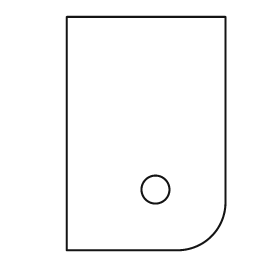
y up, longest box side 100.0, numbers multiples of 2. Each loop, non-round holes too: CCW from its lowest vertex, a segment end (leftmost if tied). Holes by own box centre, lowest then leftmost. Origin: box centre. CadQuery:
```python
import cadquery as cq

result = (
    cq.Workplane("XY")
    .moveTo(-34.0, -50.0)
    .lineTo(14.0, -50.0)
    .threePointArc((28.0, -44.0), (34.0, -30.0))
    .lineTo(34.0, 50.0)
    .lineTo(-34.0, 50.0)
    .close()
    .moveTo(4.0, -24.0)
    .circle(6.0)
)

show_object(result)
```